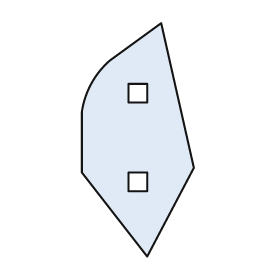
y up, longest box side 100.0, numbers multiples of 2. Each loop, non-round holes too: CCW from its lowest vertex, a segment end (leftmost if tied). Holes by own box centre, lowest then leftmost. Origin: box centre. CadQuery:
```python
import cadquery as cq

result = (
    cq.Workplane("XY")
    .moveTo(4.0, -50.0)
    .lineTo(24.0, -12.0)
    .lineTo(10.0, 50.0)
    .lineTo(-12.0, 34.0)
    .threePointArc((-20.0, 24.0), (-24.0, 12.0))
    .lineTo(-24.0, -14.0)
    .close()
    .moveTo(-4.0, -22.0)
    .lineTo(4.0, -22.0)
    .lineTo(4.0, -14.0)
    .lineTo(-4.0, -14.0)
    .close()
    .moveTo(-4.0, 16.0)
    .lineTo(4.0, 16.0)
    .lineTo(4.0, 24.0)
    .lineTo(-4.0, 24.0)
    .close()
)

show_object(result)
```